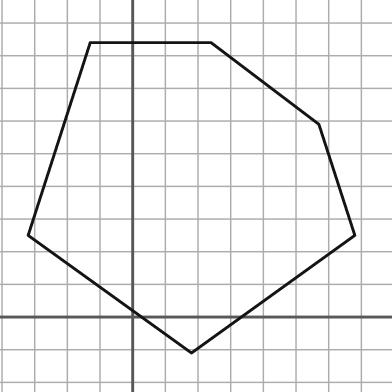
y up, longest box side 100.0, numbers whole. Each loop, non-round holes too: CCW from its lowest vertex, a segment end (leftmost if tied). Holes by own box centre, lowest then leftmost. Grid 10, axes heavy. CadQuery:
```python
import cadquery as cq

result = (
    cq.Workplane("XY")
    .moveTo(18.0, -11.0)
    .lineTo(68.0, 25.0)
    .lineTo(57.0, 59.0)
    .lineTo(24.0, 84.0)
    .lineTo(-13.0, 84.0)
    .lineTo(-32.0, 25.0)
    .close()
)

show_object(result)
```